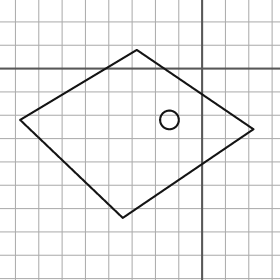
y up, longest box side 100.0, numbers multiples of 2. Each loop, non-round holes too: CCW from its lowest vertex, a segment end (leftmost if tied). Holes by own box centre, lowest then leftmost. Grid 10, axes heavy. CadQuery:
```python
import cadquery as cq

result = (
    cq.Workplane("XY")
    .moveTo(-34.0, -64.0)
    .lineTo(22.0, -26.0)
    .lineTo(-28.0, 8.0)
    .lineTo(-78.0, -22.0)
    .close()
    .moveTo(-14.0, -22.0)
    .circle(4.0)
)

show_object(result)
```